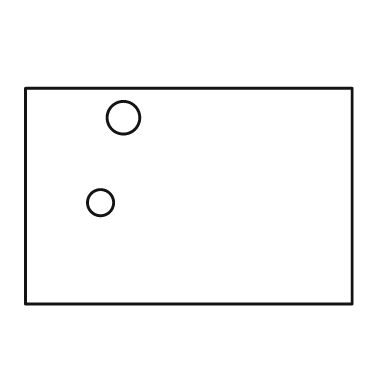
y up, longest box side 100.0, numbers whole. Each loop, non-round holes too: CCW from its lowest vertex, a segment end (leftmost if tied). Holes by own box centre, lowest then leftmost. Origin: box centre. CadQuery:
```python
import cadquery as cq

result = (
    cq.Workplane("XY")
    .moveTo(-50.0, -33.0)
    .lineTo(50.0, -33.0)
    .lineTo(50.0, 33.0)
    .lineTo(-50.0, 33.0)
    .close()
    .moveTo(-27.0, -2.0)
    .circle(4.0)
    .moveTo(-20.0, 24.0)
    .circle(5.0)
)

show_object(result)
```